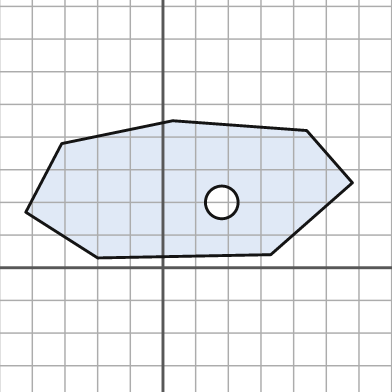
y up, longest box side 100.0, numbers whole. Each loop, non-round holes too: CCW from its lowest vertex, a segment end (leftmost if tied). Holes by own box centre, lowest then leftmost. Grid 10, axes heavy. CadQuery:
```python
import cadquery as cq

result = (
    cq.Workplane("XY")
    .moveTo(-20.0, 3.0)
    .lineTo(33.0, 4.0)
    .lineTo(58.0, 26.0)
    .lineTo(44.0, 42.0)
    .lineTo(3.0, 45.0)
    .lineTo(-31.0, 38.0)
    .lineTo(-42.0, 17.0)
    .close()
    .moveTo(18.0, 20.0)
    .circle(5.0)
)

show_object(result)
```